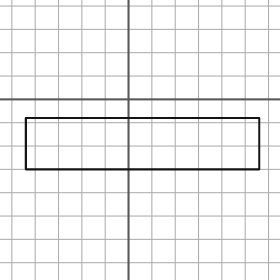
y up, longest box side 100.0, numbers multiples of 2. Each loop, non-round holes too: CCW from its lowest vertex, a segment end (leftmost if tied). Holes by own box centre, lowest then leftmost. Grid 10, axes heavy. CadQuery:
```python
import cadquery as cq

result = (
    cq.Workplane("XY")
    .moveTo(-44.0, -30.0)
    .lineTo(56.0, -30.0)
    .lineTo(56.0, -8.0)
    .lineTo(-44.0, -8.0)
    .close()
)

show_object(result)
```